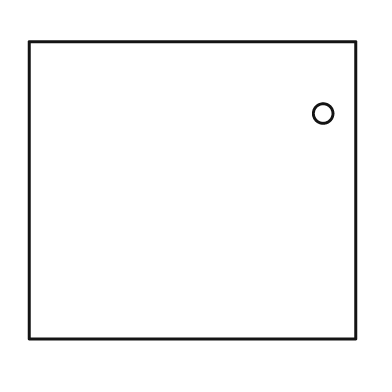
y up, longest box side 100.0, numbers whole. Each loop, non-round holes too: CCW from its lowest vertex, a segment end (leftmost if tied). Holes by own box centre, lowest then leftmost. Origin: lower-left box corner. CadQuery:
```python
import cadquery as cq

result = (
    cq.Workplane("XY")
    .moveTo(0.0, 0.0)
    .lineTo(100.0, 0.0)
    .lineTo(100.0, 91.0)
    .lineTo(0.0, 91.0)
    .close()
    .moveTo(90.0, 69.0)
    .circle(3.0)
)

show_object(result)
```